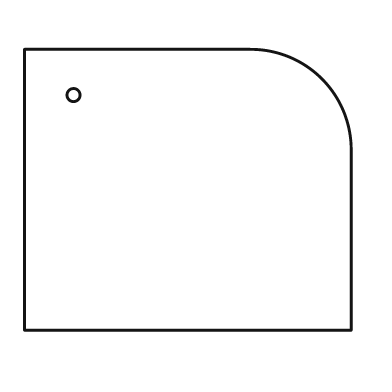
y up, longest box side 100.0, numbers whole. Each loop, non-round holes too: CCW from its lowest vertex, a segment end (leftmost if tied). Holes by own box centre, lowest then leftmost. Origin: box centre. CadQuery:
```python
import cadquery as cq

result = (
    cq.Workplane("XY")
    .moveTo(-50.0, -43.0)
    .lineTo(50.0, -43.0)
    .lineTo(50.0, 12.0)
    .threePointArc((41.0, 34.0), (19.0, 43.0))
    .lineTo(-50.0, 43.0)
    .close()
    .moveTo(-35.0, 29.0)
    .circle(2.0)
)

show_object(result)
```